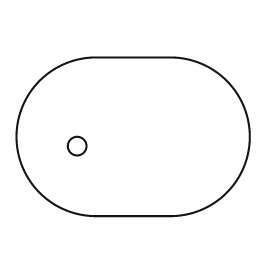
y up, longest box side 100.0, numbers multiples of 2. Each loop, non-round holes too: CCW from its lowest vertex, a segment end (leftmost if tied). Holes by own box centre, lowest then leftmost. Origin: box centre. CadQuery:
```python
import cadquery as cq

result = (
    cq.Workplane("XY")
    .moveTo(-16.0, -34.0)
    .lineTo(16.0, -34.0)
    .threePointArc((50.0, 0.0), (16.0, 34.0))
    .lineTo(-16.0, 34.0)
    .threePointArc((-50.0, 0.0), (-16.0, -34.0))
    .close()
    .moveTo(-24.0, -4.0)
    .circle(4.0)
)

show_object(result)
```